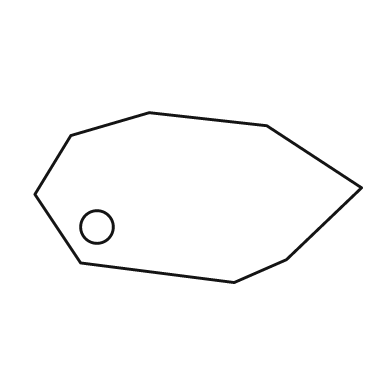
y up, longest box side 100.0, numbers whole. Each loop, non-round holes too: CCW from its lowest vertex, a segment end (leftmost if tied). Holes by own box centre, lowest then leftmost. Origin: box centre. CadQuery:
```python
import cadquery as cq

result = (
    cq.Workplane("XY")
    .moveTo(11.0, -26.0)
    .lineTo(27.0, -19.0)
    .lineTo(50.0, 3.0)
    .lineTo(21.0, 22.0)
    .lineTo(-15.0, 26.0)
    .lineTo(-39.0, 19.0)
    .lineTo(-50.0, 1.0)
    .lineTo(-36.0, -20.0)
    .close()
    .moveTo(-31.0, -9.0)
    .circle(5.0)
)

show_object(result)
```